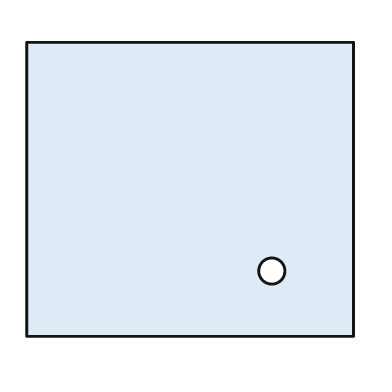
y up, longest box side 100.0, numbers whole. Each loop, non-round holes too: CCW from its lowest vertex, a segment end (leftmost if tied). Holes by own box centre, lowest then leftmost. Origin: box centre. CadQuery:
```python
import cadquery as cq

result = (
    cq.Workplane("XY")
    .moveTo(-50.0, -45.0)
    .lineTo(50.0, -45.0)
    .lineTo(50.0, 45.0)
    .lineTo(-50.0, 45.0)
    .close()
    .moveTo(25.0, -25.0)
    .circle(4.0)
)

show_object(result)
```